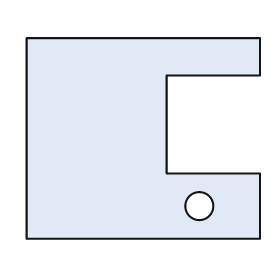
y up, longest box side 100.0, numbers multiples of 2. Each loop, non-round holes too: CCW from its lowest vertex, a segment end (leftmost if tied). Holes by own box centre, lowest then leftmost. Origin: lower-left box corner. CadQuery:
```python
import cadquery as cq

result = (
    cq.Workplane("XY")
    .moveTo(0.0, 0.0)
    .lineTo(100.0, 0.0)
    .lineTo(100.0, 28.0)
    .lineTo(60.0, 28.0)
    .lineTo(60.0, 70.0)
    .lineTo(100.0, 70.0)
    .lineTo(100.0, 86.0)
    .lineTo(0.0, 86.0)
    .close()
    .moveTo(74.0, 14.0)
    .circle(6.0)
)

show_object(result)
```